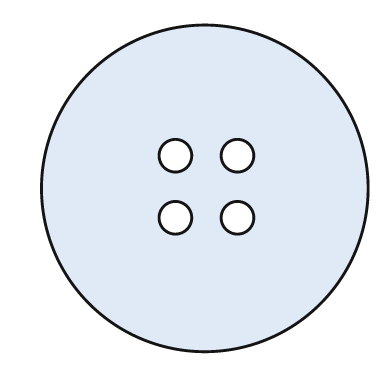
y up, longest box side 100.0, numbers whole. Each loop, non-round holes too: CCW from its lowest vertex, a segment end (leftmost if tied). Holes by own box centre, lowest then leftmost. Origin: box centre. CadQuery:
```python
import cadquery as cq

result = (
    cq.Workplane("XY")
    .moveTo(0.0, 0.0)
    .circle(50.0)
    .moveTo(-9.0, -9.0)
    .circle(5.0)
    .moveTo(10.0, -9.0)
    .circle(5.0)
    .moveTo(-9.0, 10.0)
    .circle(5.0)
    .moveTo(10.0, 10.0)
    .circle(5.0)
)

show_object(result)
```